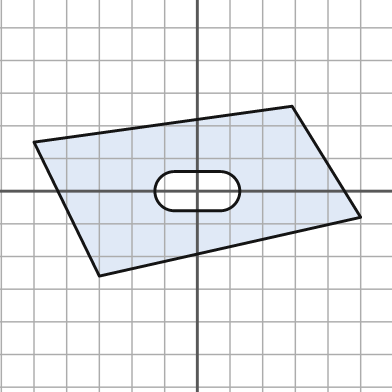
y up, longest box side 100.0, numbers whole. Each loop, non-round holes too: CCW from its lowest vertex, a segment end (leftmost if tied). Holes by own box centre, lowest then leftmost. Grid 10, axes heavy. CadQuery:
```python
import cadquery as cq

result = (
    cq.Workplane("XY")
    .moveTo(-30.0, -26.0)
    .lineTo(50.0, -8.0)
    .lineTo(29.0, 26.0)
    .lineTo(-50.0, 15.0)
    .close()
    .moveTo(-7.0, -6.0)
    .lineTo(7.0, -6.0)
    .threePointArc((13.0, 0.0), (7.0, 6.0))
    .lineTo(-7.0, 6.0)
    .threePointArc((-13.0, 0.0), (-7.0, -6.0))
    .close()
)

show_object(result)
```